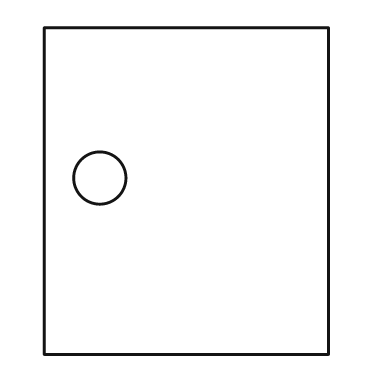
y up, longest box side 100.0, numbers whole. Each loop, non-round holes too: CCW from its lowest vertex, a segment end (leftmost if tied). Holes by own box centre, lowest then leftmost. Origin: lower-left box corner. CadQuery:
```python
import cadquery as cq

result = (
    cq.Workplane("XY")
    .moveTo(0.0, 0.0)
    .lineTo(87.0, 0.0)
    .lineTo(87.0, 100.0)
    .lineTo(0.0, 100.0)
    .close()
    .moveTo(17.0, 54.0)
    .circle(8.0)
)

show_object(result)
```